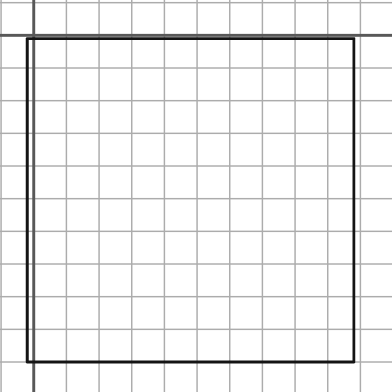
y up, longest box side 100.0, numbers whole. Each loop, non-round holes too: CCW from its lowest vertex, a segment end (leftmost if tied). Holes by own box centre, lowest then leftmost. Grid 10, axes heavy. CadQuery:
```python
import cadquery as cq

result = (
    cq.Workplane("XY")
    .moveTo(-2.0, -100.0)
    .lineTo(98.0, -100.0)
    .lineTo(98.0, -1.0)
    .lineTo(-2.0, -1.0)
    .close()
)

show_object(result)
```